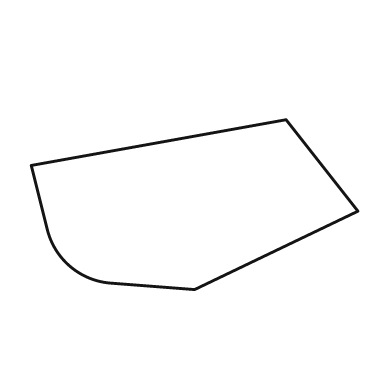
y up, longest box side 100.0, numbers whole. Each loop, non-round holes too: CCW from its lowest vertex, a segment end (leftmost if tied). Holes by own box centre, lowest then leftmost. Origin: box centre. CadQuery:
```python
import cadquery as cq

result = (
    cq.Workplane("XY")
    .moveTo(0.0, -26.0)
    .lineTo(50.0, -2.0)
    .lineTo(28.0, 26.0)
    .lineTo(-50.0, 12.0)
    .lineTo(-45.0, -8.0)
    .threePointArc((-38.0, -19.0), (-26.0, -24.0))
    .close()
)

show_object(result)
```